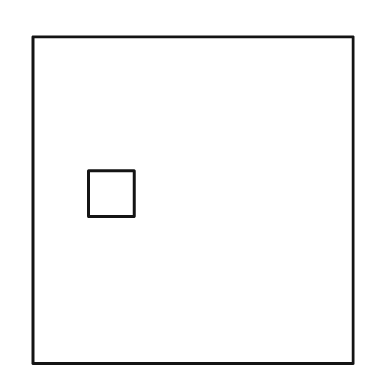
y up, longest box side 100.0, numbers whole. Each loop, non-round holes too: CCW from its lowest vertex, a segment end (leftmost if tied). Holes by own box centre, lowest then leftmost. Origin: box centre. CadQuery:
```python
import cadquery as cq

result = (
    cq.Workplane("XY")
    .moveTo(-49.0, -50.0)
    .lineTo(49.0, -50.0)
    .lineTo(49.0, 50.0)
    .lineTo(-49.0, 50.0)
    .close()
    .moveTo(-32.0, -5.0)
    .lineTo(-18.0, -5.0)
    .lineTo(-18.0, 9.0)
    .lineTo(-32.0, 9.0)
    .close()
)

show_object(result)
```